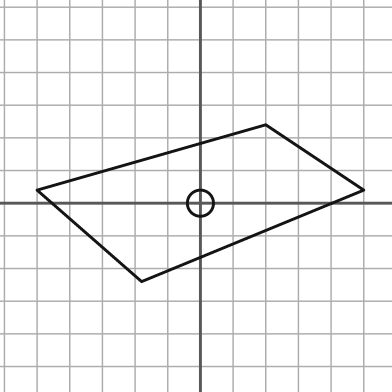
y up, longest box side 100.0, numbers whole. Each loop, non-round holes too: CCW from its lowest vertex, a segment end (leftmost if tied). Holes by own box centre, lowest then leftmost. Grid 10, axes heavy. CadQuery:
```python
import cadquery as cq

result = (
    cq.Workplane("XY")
    .moveTo(-18.0, -24.0)
    .lineTo(50.0, 4.0)
    .lineTo(20.0, 24.0)
    .lineTo(-50.0, 4.0)
    .close()
    .moveTo(0.0, 0.0)
    .circle(4.0)
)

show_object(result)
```